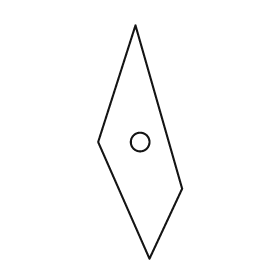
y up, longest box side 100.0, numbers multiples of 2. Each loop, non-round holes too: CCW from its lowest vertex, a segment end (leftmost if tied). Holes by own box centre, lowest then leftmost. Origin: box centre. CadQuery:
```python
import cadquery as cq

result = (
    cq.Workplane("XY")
    .moveTo(4.0, -50.0)
    .lineTo(18.0, -20.0)
    .lineTo(-2.0, 50.0)
    .lineTo(-18.0, 0.0)
    .close()
    .moveTo(0.0, 0.0)
    .circle(4.0)
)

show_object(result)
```